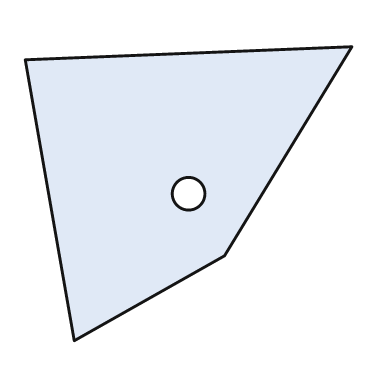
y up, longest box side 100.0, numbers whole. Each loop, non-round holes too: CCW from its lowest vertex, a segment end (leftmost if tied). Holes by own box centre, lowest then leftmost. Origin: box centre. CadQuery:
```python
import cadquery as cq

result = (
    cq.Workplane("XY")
    .moveTo(-35.0, -45.0)
    .lineTo(11.0, -19.0)
    .lineTo(50.0, 45.0)
    .lineTo(-50.0, 41.0)
    .close()
    .moveTo(0.0, 0.0)
    .circle(5.0)
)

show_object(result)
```